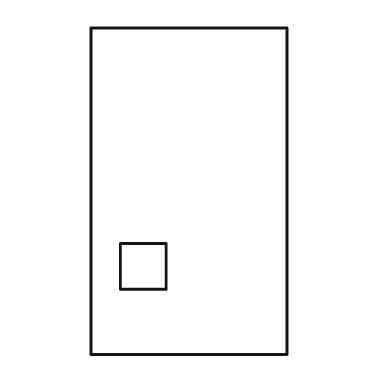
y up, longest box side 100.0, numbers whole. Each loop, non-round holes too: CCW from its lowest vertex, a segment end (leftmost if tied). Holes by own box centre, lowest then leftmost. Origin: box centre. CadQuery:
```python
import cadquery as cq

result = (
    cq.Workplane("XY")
    .moveTo(-30.0, -50.0)
    .lineTo(30.0, -50.0)
    .lineTo(30.0, 50.0)
    .lineTo(-30.0, 50.0)
    .close()
    .moveTo(-21.0, -30.0)
    .lineTo(-7.0, -30.0)
    .lineTo(-7.0, -16.0)
    .lineTo(-21.0, -16.0)
    .close()
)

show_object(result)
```